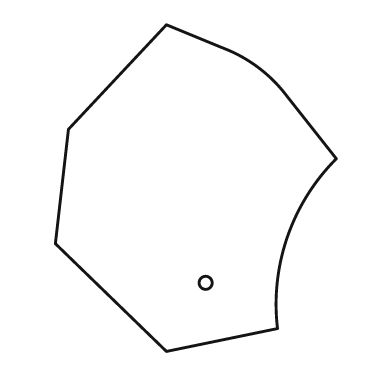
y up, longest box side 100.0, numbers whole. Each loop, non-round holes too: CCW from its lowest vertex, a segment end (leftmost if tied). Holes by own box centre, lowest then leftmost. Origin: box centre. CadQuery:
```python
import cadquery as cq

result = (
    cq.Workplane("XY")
    .moveTo(-9.0, -50.0)
    .lineTo(25.0, -43.0)
    .threePointArc((28.0, -15.0), (43.0, 9.0))
    .lineTo(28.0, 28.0)
    .threePointArc((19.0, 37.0), (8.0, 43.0))
    .lineTo(-9.0, 50.0)
    .lineTo(-39.0, 18.0)
    .lineTo(-43.0, -17.0)
    .close()
    .moveTo(3.0, -29.0)
    .circle(2.0)
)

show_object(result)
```